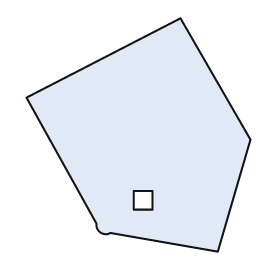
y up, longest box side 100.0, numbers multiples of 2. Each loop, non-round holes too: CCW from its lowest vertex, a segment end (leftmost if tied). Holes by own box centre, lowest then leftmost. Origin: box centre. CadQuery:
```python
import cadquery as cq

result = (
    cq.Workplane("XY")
    .moveTo(34.0, -50.0)
    .lineTo(48.0, -2.0)
    .lineTo(18.0, 50.0)
    .lineTo(-48.0, 16.0)
    .lineTo(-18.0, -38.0)
    .threePointArc((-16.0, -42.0), (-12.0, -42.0))
    .close()
    .moveTo(-2.0, -32.0)
    .lineTo(6.0, -32.0)
    .lineTo(6.0, -24.0)
    .lineTo(-2.0, -24.0)
    .close()
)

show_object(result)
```